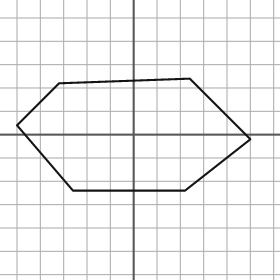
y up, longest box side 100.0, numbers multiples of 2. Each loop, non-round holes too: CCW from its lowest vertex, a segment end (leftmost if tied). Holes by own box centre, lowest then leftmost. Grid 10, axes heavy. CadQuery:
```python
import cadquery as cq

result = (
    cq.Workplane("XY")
    .moveTo(-26.0, -24.0)
    .lineTo(22.0, -24.0)
    .lineTo(50.0, -2.0)
    .lineTo(24.0, 24.0)
    .lineTo(-32.0, 22.0)
    .lineTo(-50.0, 4.0)
    .close()
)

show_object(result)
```